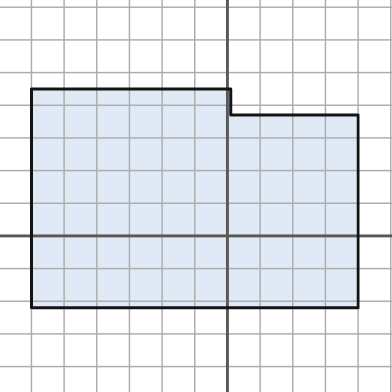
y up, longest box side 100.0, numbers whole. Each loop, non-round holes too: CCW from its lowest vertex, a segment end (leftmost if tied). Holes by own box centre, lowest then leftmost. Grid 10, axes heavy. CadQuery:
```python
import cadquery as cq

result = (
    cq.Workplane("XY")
    .moveTo(-60.0, -22.0)
    .lineTo(40.0, -22.0)
    .lineTo(40.0, 37.0)
    .lineTo(1.0, 37.0)
    .lineTo(1.0, 45.0)
    .lineTo(-60.0, 45.0)
    .close()
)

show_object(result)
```